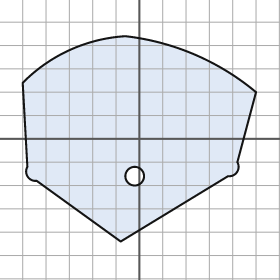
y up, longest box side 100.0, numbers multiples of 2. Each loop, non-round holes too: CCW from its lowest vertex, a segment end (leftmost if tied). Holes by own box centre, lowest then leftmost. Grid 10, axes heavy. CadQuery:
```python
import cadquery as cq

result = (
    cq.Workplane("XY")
    .moveTo(-8.0, -44.0)
    .lineTo(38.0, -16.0)
    .threePointArc((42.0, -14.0), (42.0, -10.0))
    .lineTo(50.0, 20.0)
    .threePointArc((24.0, 36.0), (-6.0, 44.0))
    .threePointArc((-30.0, 38.0), (-50.0, 24.0))
    .lineTo(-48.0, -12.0)
    .threePointArc((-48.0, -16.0), (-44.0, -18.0))
    .close()
    .moveTo(-2.0, -16.0)
    .circle(4.0)
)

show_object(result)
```